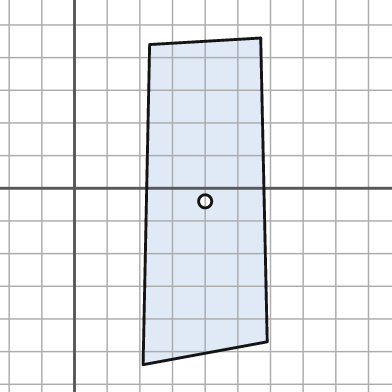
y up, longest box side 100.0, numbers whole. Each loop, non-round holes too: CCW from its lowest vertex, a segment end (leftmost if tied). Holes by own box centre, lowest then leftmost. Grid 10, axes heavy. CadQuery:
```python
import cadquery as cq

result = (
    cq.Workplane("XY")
    .moveTo(21.0, -54.0)
    .lineTo(59.0, -47.0)
    .lineTo(57.0, 46.0)
    .lineTo(23.0, 44.0)
    .close()
    .moveTo(40.0, -4.0)
    .circle(2.0)
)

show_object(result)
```